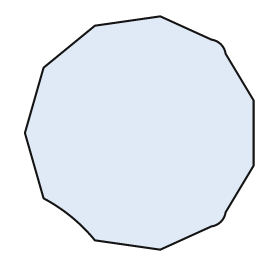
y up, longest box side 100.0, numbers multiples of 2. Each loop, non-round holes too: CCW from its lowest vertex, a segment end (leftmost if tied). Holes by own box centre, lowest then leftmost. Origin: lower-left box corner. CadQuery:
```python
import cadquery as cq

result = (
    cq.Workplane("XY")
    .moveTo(58.0, 0.0)
    .lineTo(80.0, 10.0)
    .threePointArc((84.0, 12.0), (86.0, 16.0))
    .lineTo(98.0, 36.0)
    .lineTo(98.0, 64.0)
    .lineTo(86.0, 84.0)
    .threePointArc((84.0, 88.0), (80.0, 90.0))
    .lineTo(58.0, 100.0)
    .lineTo(30.0, 96.0)
    .lineTo(8.0, 78.0)
    .lineTo(0.0, 50.0)
    .lineTo(8.0, 22.0)
    .threePointArc((20.0, 14.0), (30.0, 4.0))
    .close()
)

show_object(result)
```